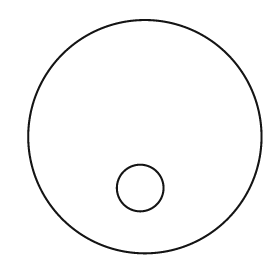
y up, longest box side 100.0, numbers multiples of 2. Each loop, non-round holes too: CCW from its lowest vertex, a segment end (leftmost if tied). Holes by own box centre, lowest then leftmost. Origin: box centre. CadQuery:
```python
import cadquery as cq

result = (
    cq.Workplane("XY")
    .moveTo(0.0, 0.0)
    .circle(50.0)
    .moveTo(-2.0, -22.0)
    .circle(10.0)
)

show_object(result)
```